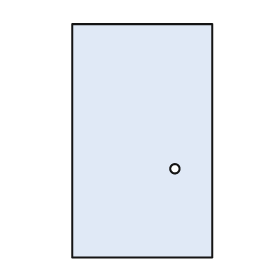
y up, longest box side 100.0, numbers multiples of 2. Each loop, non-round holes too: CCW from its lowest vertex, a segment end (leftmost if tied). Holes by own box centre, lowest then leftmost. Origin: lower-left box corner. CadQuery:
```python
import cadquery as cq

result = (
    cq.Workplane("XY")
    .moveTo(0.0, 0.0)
    .lineTo(60.0, 0.0)
    .lineTo(60.0, 100.0)
    .lineTo(0.0, 100.0)
    .close()
    .moveTo(44.0, 38.0)
    .circle(2.0)
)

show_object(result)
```